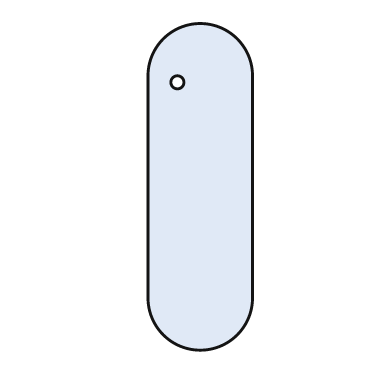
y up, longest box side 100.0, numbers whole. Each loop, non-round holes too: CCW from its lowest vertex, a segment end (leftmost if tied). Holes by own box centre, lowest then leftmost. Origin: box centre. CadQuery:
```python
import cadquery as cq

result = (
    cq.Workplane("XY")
    .moveTo(-16.0, -34.0)
    .threePointArc((0.0, -50.0), (16.0, -34.0))
    .lineTo(16.0, 34.0)
    .threePointArc((0.0, 50.0), (-16.0, 34.0))
    .close()
    .moveTo(-7.0, 32.0)
    .circle(2.0)
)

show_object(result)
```